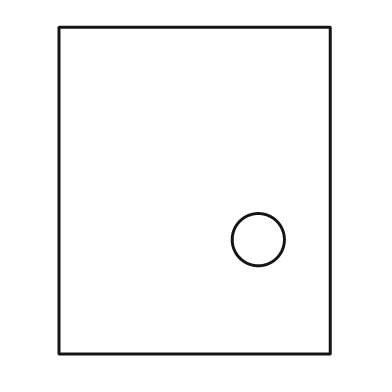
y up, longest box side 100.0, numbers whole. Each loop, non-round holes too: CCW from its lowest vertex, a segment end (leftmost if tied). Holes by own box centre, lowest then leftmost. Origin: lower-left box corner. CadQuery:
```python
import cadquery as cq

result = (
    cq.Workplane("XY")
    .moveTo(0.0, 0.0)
    .lineTo(83.0, 0.0)
    .lineTo(83.0, 100.0)
    .lineTo(0.0, 100.0)
    .close()
    .moveTo(61.0, 35.0)
    .circle(8.0)
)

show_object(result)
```